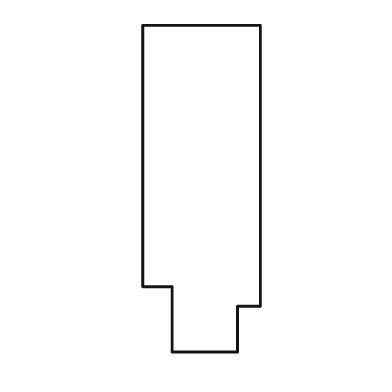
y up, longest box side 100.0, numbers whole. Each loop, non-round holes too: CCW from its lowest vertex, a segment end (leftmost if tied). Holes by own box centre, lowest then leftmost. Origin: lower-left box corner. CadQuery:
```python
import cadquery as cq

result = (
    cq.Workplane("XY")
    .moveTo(9.0, 0.0)
    .lineTo(29.0, 0.0)
    .lineTo(29.0, 14.0)
    .lineTo(36.0, 14.0)
    .lineTo(36.0, 100.0)
    .lineTo(0.0, 100.0)
    .lineTo(0.0, 20.0)
    .lineTo(9.0, 20.0)
    .close()
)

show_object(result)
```